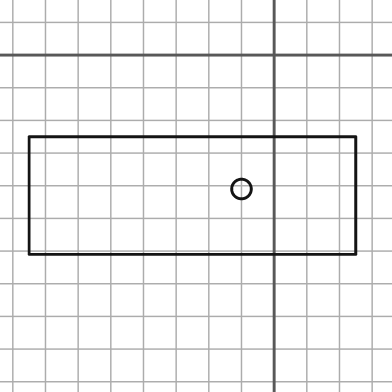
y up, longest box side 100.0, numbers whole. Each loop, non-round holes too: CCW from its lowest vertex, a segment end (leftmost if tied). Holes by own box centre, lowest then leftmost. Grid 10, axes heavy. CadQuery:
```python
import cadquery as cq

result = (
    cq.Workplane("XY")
    .moveTo(-75.0, -61.0)
    .lineTo(25.0, -61.0)
    .lineTo(25.0, -25.0)
    .lineTo(-75.0, -25.0)
    .close()
    .moveTo(-10.0, -41.0)
    .circle(3.0)
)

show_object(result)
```